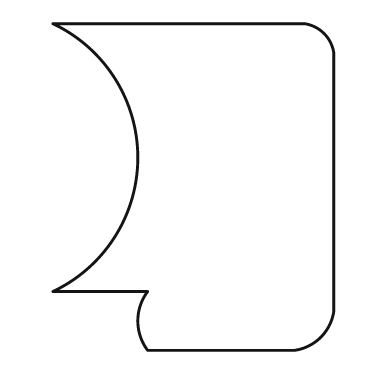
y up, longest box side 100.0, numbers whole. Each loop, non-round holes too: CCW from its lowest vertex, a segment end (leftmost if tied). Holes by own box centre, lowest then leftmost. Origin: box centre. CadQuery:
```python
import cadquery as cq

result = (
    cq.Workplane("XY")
    .moveTo(-14.0, -50.0)
    .lineTo(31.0, -50.0)
    .threePointArc((39.0, -46.0), (43.0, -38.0))
    .lineTo(43.0, 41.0)
    .threePointArc((40.0, 47.0), (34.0, 50.0))
    .lineTo(-43.0, 50.0)
    .threePointArc((-17.0, 9.0), (-43.0, -32.0))
    .lineTo(-14.0, -32.0)
    .threePointArc((-17.0, -41.0), (-14.0, -50.0))
    .close()
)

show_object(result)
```